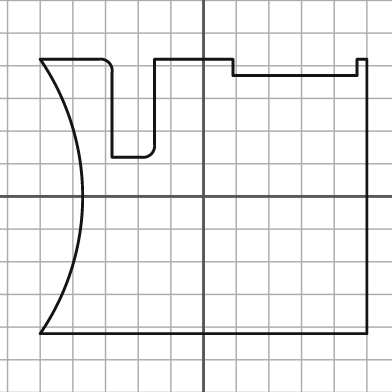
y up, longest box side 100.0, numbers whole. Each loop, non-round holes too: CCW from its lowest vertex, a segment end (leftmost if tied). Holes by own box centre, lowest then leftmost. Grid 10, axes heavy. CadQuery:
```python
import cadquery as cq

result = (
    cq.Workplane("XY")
    .moveTo(-50.0, -42.0)
    .lineTo(50.0, -42.0)
    .lineTo(50.0, 42.0)
    .lineTo(47.0, 42.0)
    .lineTo(47.0, 37.0)
    .lineTo(9.0, 37.0)
    .lineTo(9.0, 42.0)
    .lineTo(-15.0, 42.0)
    .lineTo(-15.0, 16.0)
    .threePointArc((-16.0, 13.0), (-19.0, 12.0))
    .lineTo(-28.0, 12.0)
    .lineTo(-28.0, 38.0)
    .threePointArc((-29.0, 41.0), (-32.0, 42.0))
    .lineTo(-50.0, 42.0)
    .threePointArc((-37.0, 0.0), (-50.0, -42.0))
    .close()
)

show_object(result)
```